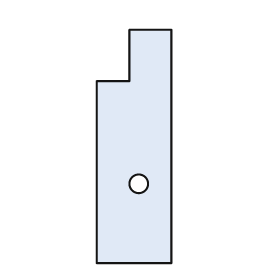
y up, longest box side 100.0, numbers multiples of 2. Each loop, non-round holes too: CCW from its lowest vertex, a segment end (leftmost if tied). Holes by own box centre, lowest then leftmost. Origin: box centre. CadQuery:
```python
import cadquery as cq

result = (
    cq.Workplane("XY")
    .moveTo(-16.0, -50.0)
    .lineTo(16.0, -50.0)
    .lineTo(16.0, 50.0)
    .lineTo(-2.0, 50.0)
    .lineTo(-2.0, 28.0)
    .lineTo(-16.0, 28.0)
    .close()
    .moveTo(2.0, -16.0)
    .circle(4.0)
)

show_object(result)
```